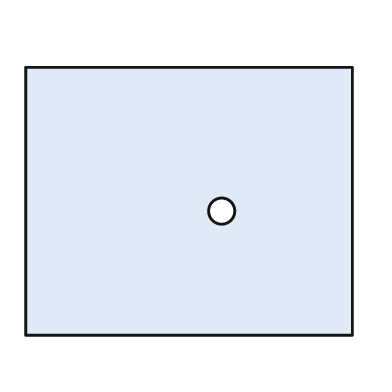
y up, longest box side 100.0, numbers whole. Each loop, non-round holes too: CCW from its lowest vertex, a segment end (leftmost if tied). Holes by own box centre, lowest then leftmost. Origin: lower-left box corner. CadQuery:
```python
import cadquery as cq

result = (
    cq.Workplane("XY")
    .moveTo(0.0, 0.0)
    .lineTo(100.0, 0.0)
    .lineTo(100.0, 82.0)
    .lineTo(0.0, 82.0)
    .close()
    .moveTo(60.0, 38.0)
    .circle(4.0)
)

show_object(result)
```